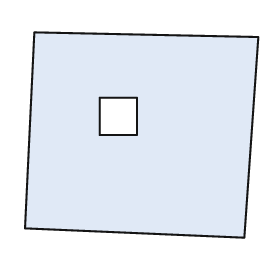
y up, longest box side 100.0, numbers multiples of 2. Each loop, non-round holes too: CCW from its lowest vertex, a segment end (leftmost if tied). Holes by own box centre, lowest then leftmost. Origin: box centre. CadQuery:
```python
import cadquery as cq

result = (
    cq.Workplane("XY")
    .moveTo(44.0, -44.0)
    .lineTo(50.0, 42.0)
    .lineTo(-46.0, 44.0)
    .lineTo(-50.0, -40.0)
    .close()
    .moveTo(-18.0, 0.0)
    .lineTo(-2.0, 0.0)
    .lineTo(-2.0, 16.0)
    .lineTo(-18.0, 16.0)
    .close()
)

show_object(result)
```